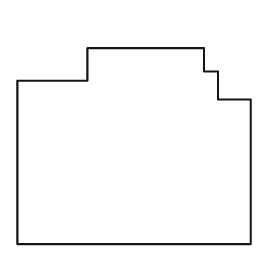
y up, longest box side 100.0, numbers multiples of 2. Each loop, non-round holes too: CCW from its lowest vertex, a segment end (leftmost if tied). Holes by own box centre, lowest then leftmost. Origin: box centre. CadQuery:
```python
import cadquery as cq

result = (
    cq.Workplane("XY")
    .moveTo(-50.0, -42.0)
    .lineTo(50.0, -42.0)
    .lineTo(50.0, 20.0)
    .lineTo(36.0, 20.0)
    .lineTo(36.0, 32.0)
    .lineTo(30.0, 32.0)
    .lineTo(30.0, 42.0)
    .lineTo(-20.0, 42.0)
    .lineTo(-20.0, 28.0)
    .lineTo(-50.0, 28.0)
    .close()
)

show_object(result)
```